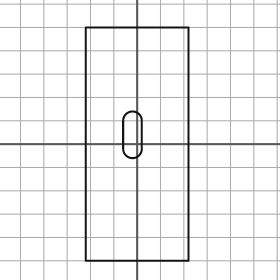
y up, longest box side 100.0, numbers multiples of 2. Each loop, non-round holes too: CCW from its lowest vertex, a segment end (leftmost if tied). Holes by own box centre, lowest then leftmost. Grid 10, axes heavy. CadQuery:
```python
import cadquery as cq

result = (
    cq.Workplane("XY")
    .moveTo(-22.0, -50.0)
    .lineTo(22.0, -50.0)
    .lineTo(22.0, 50.0)
    .lineTo(-22.0, 50.0)
    .close()
    .moveTo(-6.0, -2.0)
    .threePointArc((-2.0, -6.0), (2.0, -2.0))
    .lineTo(2.0, 10.0)
    .threePointArc((-2.0, 14.0), (-6.0, 10.0))
    .close()
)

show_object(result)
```